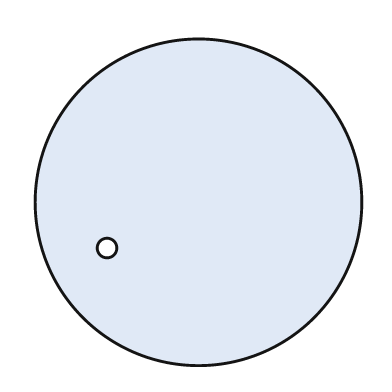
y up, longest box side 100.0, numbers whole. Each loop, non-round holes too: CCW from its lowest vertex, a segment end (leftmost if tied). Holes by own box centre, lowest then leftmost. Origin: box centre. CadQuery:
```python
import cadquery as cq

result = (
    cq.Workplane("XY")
    .moveTo(0.0, 0.0)
    .circle(50.0)
    .moveTo(-28.0, -14.0)
    .circle(3.0)
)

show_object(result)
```